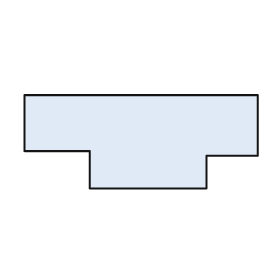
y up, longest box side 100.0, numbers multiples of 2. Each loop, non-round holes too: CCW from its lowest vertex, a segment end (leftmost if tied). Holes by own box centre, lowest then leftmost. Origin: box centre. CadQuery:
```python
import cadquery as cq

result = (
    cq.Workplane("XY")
    .moveTo(-22.0, -20.0)
    .lineTo(28.0, -20.0)
    .lineTo(28.0, -6.0)
    .lineTo(50.0, -6.0)
    .lineTo(50.0, 20.0)
    .lineTo(-50.0, 20.0)
    .lineTo(-50.0, -4.0)
    .lineTo(-22.0, -4.0)
    .close()
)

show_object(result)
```